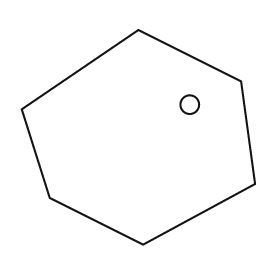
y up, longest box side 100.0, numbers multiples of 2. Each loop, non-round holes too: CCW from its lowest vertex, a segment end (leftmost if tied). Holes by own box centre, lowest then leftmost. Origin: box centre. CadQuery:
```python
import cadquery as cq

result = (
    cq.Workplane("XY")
    .moveTo(2.0, -46.0)
    .lineTo(50.0, -20.0)
    .lineTo(44.0, 24.0)
    .lineTo(0.0, 46.0)
    .lineTo(-50.0, 12.0)
    .lineTo(-38.0, -26.0)
    .close()
    .moveTo(22.0, 14.0)
    .circle(4.0)
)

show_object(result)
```